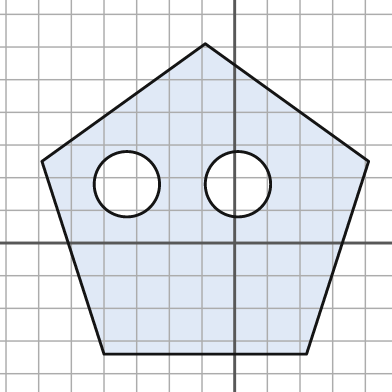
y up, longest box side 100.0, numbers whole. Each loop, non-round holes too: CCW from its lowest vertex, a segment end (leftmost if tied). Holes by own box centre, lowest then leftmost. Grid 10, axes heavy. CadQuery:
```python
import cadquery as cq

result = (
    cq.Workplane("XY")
    .moveTo(-40.0, -34.0)
    .lineTo(22.0, -34.0)
    .lineTo(41.0, 25.0)
    .lineTo(-9.0, 61.0)
    .lineTo(-59.0, 25.0)
    .close()
    .moveTo(-33.0, 18.0)
    .circle(10.0)
    .moveTo(1.0, 18.0)
    .circle(10.0)
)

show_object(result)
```